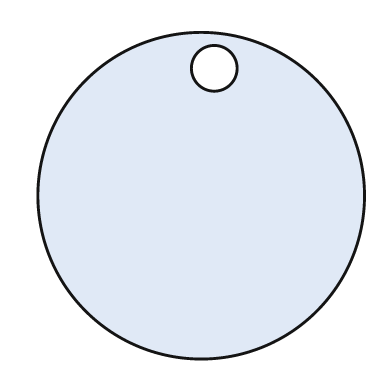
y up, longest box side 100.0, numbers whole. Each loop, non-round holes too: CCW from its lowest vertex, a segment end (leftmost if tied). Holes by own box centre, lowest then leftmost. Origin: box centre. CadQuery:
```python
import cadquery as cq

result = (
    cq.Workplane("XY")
    .moveTo(0.0, 0.0)
    .circle(50.0)
    .moveTo(4.0, 39.0)
    .circle(7.0)
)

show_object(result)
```